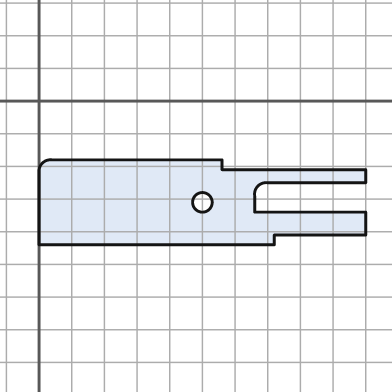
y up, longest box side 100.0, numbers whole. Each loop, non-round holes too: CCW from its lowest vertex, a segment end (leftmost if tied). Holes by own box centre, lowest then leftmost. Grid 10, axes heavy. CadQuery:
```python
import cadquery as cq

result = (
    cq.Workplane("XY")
    .moveTo(0.0, -44.0)
    .lineTo(72.0, -44.0)
    .lineTo(72.0, -41.0)
    .lineTo(100.0, -41.0)
    .lineTo(100.0, -34.0)
    .lineTo(66.0, -34.0)
    .lineTo(66.0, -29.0)
    .threePointArc((67.0, -26.0), (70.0, -25.0))
    .lineTo(100.0, -25.0)
    .lineTo(100.0, -21.0)
    .lineTo(56.0, -21.0)
    .lineTo(56.0, -18.0)
    .lineTo(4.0, -18.0)
    .threePointArc((1.0, -19.0), (0.0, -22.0))
    .close()
    .moveTo(50.0, -31.0)
    .circle(3.0)
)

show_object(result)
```